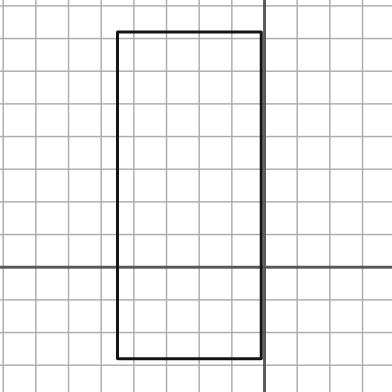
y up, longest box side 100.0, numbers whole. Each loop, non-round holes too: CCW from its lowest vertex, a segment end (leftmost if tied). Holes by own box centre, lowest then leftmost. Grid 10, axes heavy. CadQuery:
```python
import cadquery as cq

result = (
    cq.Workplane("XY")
    .moveTo(-45.0, -28.0)
    .lineTo(-1.0, -28.0)
    .lineTo(-1.0, 72.0)
    .lineTo(-45.0, 72.0)
    .close()
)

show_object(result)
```